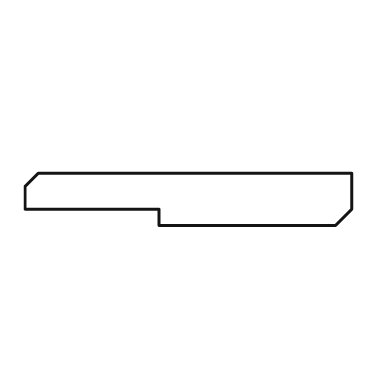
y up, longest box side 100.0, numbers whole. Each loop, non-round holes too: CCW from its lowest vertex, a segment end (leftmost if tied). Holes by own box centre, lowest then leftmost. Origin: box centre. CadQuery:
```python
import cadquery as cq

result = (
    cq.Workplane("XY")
    .moveTo(-9.0, -8.0)
    .lineTo(45.0, -8.0)
    .lineTo(50.0, -3.0)
    .lineTo(50.0, 8.0)
    .lineTo(-46.0, 8.0)
    .lineTo(-50.0, 4.0)
    .lineTo(-50.0, -3.0)
    .lineTo(-9.0, -3.0)
    .close()
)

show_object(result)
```